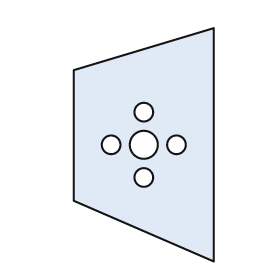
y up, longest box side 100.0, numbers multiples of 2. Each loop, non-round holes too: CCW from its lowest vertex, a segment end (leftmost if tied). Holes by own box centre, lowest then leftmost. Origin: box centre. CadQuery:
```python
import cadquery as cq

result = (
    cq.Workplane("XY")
    .moveTo(30.0, -50.0)
    .lineTo(30.0, 50.0)
    .lineTo(-30.0, 32.0)
    .lineTo(-30.0, -24.0)
    .close()
    .moveTo(0.0, -14.0)
    .circle(4.0)
    .moveTo(-14.0, 0.0)
    .circle(4.0)
    .moveTo(0.0, 0.0)
    .circle(6.0)
    .moveTo(14.0, 0.0)
    .circle(4.0)
    .moveTo(0.0, 14.0)
    .circle(4.0)
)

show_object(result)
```